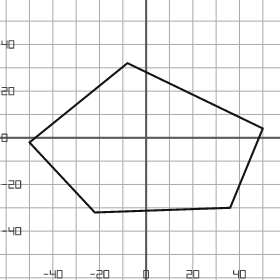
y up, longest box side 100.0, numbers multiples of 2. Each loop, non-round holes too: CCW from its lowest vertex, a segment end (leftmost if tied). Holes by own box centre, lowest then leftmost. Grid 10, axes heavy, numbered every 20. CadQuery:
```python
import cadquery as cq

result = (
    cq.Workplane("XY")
    .moveTo(-22.0, -32.0)
    .lineTo(36.0, -30.0)
    .lineTo(50.0, 4.0)
    .lineTo(-8.0, 32.0)
    .lineTo(-50.0, -2.0)
    .close()
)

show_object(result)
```